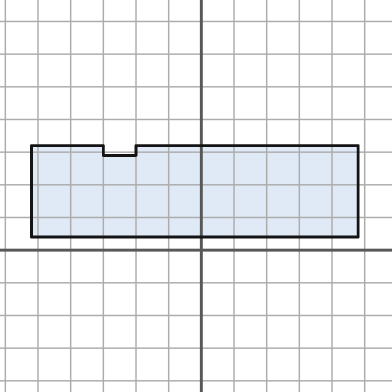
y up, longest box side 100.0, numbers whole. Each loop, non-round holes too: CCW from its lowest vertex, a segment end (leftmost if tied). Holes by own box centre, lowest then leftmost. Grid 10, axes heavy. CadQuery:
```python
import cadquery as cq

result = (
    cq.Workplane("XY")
    .moveTo(-52.0, 4.0)
    .lineTo(48.0, 4.0)
    .lineTo(48.0, 32.0)
    .lineTo(-20.0, 32.0)
    .lineTo(-20.0, 29.0)
    .lineTo(-30.0, 29.0)
    .lineTo(-30.0, 32.0)
    .lineTo(-52.0, 32.0)
    .close()
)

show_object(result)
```